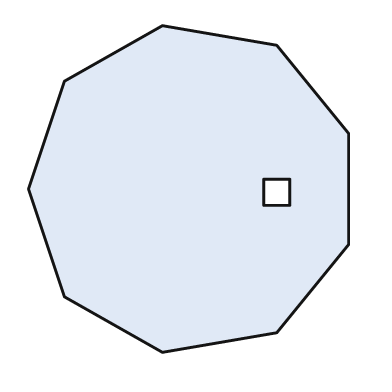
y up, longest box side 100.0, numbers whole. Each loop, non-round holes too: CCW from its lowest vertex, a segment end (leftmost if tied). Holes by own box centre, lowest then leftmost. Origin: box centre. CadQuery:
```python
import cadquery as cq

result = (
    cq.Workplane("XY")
    .moveTo(-8.0, -50.0)
    .lineTo(27.0, -44.0)
    .lineTo(49.0, -17.0)
    .lineTo(49.0, 17.0)
    .lineTo(27.0, 44.0)
    .lineTo(-8.0, 50.0)
    .lineTo(-38.0, 33.0)
    .lineTo(-49.0, 0.0)
    .lineTo(-38.0, -33.0)
    .close()
    .moveTo(23.0, -5.0)
    .lineTo(31.0, -5.0)
    .lineTo(31.0, 3.0)
    .lineTo(23.0, 3.0)
    .close()
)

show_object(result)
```